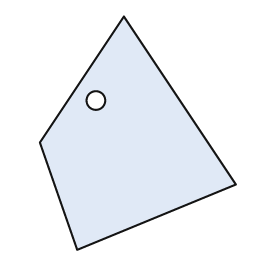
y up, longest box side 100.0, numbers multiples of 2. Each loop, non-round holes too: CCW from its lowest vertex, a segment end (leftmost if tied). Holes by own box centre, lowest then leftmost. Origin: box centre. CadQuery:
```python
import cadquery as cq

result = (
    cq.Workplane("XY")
    .moveTo(-26.0, -50.0)
    .lineTo(42.0, -22.0)
    .lineTo(-6.0, 50.0)
    .lineTo(-42.0, -4.0)
    .close()
    .moveTo(-18.0, 14.0)
    .circle(4.0)
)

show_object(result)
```